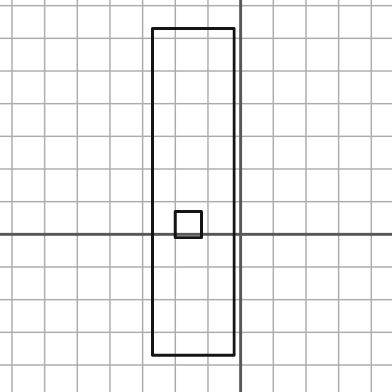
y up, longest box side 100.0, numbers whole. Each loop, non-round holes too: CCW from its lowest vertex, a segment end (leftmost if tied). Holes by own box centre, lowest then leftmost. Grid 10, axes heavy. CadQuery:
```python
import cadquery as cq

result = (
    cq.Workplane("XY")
    .moveTo(-27.0, -37.0)
    .lineTo(-2.0, -37.0)
    .lineTo(-2.0, 63.0)
    .lineTo(-27.0, 63.0)
    .close()
    .moveTo(-20.0, -1.0)
    .lineTo(-12.0, -1.0)
    .lineTo(-12.0, 7.0)
    .lineTo(-20.0, 7.0)
    .close()
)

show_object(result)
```